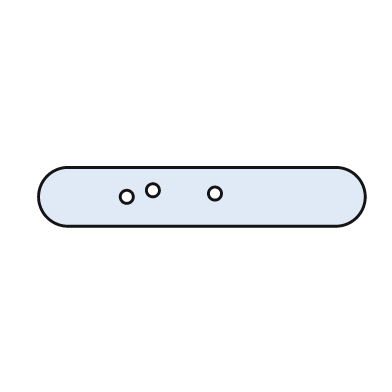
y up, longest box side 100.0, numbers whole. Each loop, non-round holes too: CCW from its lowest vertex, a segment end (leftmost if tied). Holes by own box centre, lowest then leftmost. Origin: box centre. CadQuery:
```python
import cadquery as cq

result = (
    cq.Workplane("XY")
    .moveTo(-41.0, -9.0)
    .lineTo(41.0, -9.0)
    .threePointArc((50.0, 0.0), (41.0, 9.0))
    .lineTo(-41.0, 9.0)
    .threePointArc((-50.0, 0.0), (-41.0, -9.0))
    .close()
    .moveTo(-23.0, 0.0)
    .circle(2.0)
    .moveTo(4.0, 1.0)
    .circle(2.0)
    .moveTo(-15.0, 2.0)
    .circle(2.0)
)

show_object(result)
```